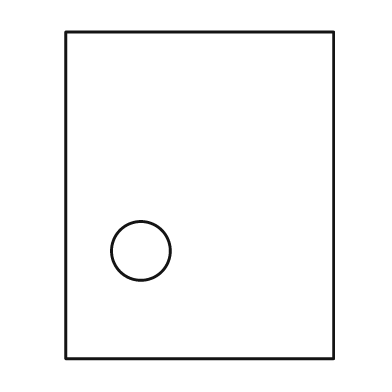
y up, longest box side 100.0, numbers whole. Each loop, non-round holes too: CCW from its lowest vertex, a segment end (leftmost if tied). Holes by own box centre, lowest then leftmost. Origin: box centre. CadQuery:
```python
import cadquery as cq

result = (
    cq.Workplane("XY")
    .moveTo(-41.0, -50.0)
    .lineTo(41.0, -50.0)
    .lineTo(41.0, 50.0)
    .lineTo(-41.0, 50.0)
    .close()
    .moveTo(-18.0, -17.0)
    .circle(9.0)
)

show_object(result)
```